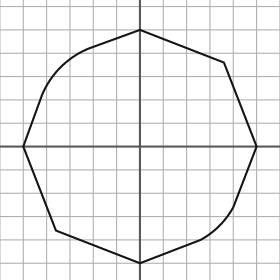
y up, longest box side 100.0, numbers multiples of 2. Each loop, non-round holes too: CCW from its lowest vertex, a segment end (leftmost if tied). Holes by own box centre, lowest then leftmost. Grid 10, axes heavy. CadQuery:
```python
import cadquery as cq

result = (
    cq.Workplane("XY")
    .moveTo(0.0, -50.0)
    .lineTo(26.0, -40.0)
    .threePointArc((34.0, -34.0), (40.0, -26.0))
    .lineTo(50.0, 0.0)
    .lineTo(36.0, 36.0)
    .lineTo(0.0, 50.0)
    .lineTo(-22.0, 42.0)
    .threePointArc((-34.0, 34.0), (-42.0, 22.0))
    .lineTo(-50.0, 0.0)
    .lineTo(-36.0, -36.0)
    .close()
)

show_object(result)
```